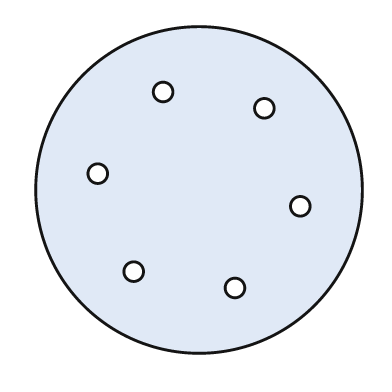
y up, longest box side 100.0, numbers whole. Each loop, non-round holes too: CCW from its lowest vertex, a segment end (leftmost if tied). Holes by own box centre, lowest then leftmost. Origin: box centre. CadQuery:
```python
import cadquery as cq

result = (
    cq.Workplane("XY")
    .moveTo(0.0, 0.0)
    .circle(50.0)
    .moveTo(11.0, -30.0)
    .circle(3.0)
    .moveTo(-20.0, -25.0)
    .circle(3.0)
    .moveTo(31.0, -5.0)
    .circle(3.0)
    .moveTo(-31.0, 5.0)
    .circle(3.0)
    .moveTo(20.0, 25.0)
    .circle(3.0)
    .moveTo(-11.0, 30.0)
    .circle(3.0)
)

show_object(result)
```